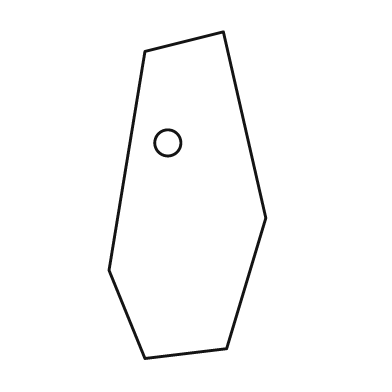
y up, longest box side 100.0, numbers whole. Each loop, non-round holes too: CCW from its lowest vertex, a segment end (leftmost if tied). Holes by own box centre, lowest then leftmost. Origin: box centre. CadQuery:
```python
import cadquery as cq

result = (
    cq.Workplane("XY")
    .moveTo(-13.0, -50.0)
    .lineTo(12.0, -47.0)
    .lineTo(24.0, -7.0)
    .lineTo(11.0, 50.0)
    .lineTo(-13.0, 44.0)
    .lineTo(-24.0, -23.0)
    .close()
    .moveTo(-6.0, 16.0)
    .circle(4.0)
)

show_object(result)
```